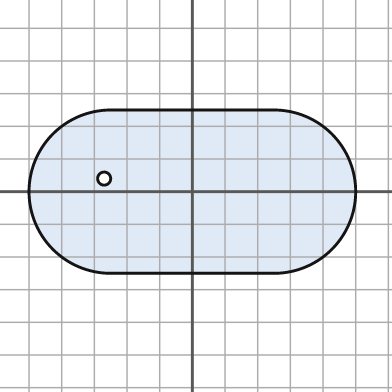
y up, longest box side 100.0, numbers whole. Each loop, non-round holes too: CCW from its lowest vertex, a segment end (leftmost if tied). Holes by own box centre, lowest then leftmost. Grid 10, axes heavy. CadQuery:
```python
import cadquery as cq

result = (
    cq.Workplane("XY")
    .moveTo(-25.0, -25.0)
    .lineTo(25.0, -25.0)
    .threePointArc((50.0, 0.0), (25.0, 25.0))
    .lineTo(-25.0, 25.0)
    .threePointArc((-50.0, 0.0), (-25.0, -25.0))
    .close()
    .moveTo(-27.0, 4.0)
    .circle(2.0)
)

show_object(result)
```